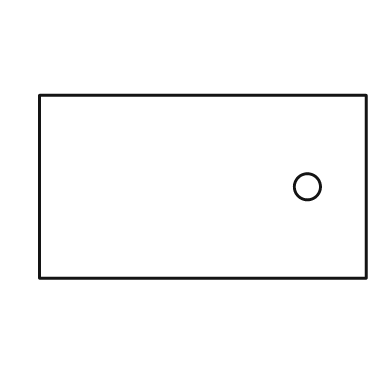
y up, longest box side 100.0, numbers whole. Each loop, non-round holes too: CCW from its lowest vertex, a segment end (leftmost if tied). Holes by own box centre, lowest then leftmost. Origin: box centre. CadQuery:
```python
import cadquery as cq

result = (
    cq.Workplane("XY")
    .moveTo(-50.0, -28.0)
    .lineTo(50.0, -28.0)
    .lineTo(50.0, 28.0)
    .lineTo(-50.0, 28.0)
    .close()
    .moveTo(32.0, 0.0)
    .circle(4.0)
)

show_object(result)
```